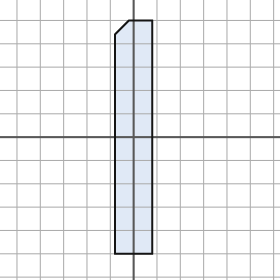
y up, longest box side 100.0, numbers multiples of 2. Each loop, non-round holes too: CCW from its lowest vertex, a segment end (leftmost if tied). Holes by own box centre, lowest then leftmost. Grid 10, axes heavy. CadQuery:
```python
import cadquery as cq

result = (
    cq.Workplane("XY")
    .moveTo(-8.0, -50.0)
    .lineTo(8.0, -50.0)
    .lineTo(8.0, 50.0)
    .lineTo(-2.0, 50.0)
    .lineTo(-8.0, 44.0)
    .close()
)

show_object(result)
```